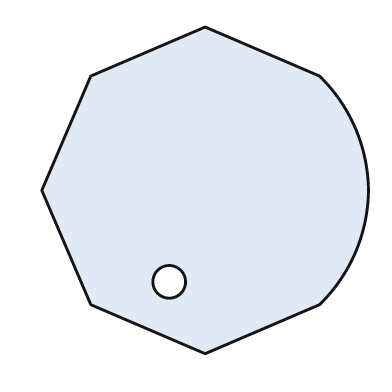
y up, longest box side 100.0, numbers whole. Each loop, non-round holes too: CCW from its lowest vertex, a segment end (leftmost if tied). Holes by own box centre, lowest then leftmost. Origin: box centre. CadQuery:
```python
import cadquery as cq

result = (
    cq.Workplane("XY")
    .moveTo(0.0, -50.0)
    .lineTo(35.0, -35.0)
    .threePointArc((46.0, -19.0), (50.0, 0.0))
    .threePointArc((46.0, 19.0), (35.0, 35.0))
    .lineTo(0.0, 50.0)
    .lineTo(-35.0, 35.0)
    .lineTo(-50.0, 0.0)
    .lineTo(-35.0, -35.0)
    .close()
    .moveTo(-11.0, -28.0)
    .circle(5.0)
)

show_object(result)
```